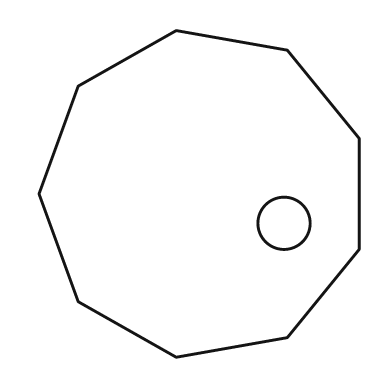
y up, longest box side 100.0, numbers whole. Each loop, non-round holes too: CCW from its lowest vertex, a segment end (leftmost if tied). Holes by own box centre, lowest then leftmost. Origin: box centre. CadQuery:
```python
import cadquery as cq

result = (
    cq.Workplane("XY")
    .moveTo(-7.0, -50.0)
    .lineTo(27.0, -44.0)
    .lineTo(49.0, -17.0)
    .lineTo(49.0, 17.0)
    .lineTo(27.0, 44.0)
    .lineTo(-7.0, 50.0)
    .lineTo(-37.0, 33.0)
    .lineTo(-49.0, 0.0)
    .lineTo(-37.0, -33.0)
    .close()
    .moveTo(26.0, -9.0)
    .circle(8.0)
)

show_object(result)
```